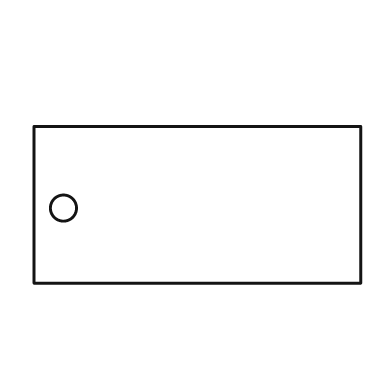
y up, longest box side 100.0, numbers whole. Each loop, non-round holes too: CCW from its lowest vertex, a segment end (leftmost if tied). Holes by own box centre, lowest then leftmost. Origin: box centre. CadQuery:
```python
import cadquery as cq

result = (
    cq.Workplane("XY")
    .moveTo(-50.0, -24.0)
    .lineTo(50.0, -24.0)
    .lineTo(50.0, 24.0)
    .lineTo(-50.0, 24.0)
    .close()
    .moveTo(-41.0, -1.0)
    .circle(4.0)
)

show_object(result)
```